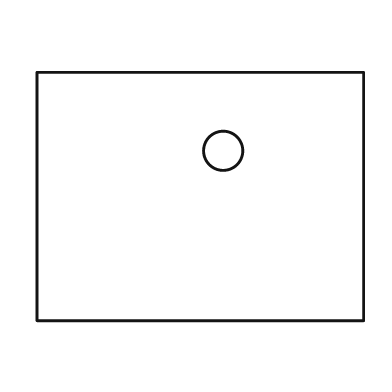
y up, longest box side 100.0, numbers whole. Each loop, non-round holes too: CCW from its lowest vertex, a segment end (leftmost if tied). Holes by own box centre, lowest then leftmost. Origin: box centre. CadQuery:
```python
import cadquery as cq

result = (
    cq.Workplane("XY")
    .moveTo(-50.0, -38.0)
    .lineTo(50.0, -38.0)
    .lineTo(50.0, 38.0)
    .lineTo(-50.0, 38.0)
    .close()
    .moveTo(7.0, 14.0)
    .circle(6.0)
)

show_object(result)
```